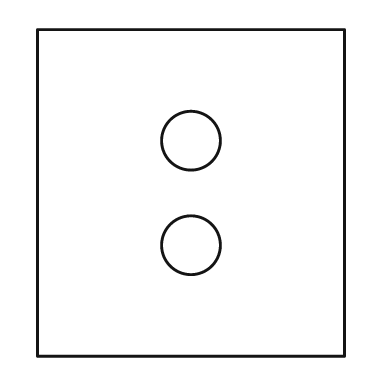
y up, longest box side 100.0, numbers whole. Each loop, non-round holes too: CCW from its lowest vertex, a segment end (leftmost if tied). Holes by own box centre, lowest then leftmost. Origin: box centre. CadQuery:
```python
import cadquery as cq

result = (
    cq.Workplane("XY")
    .moveTo(-47.0, -50.0)
    .lineTo(47.0, -50.0)
    .lineTo(47.0, 50.0)
    .lineTo(-47.0, 50.0)
    .close()
    .moveTo(0.0, -16.0)
    .circle(9.0)
    .moveTo(0.0, 16.0)
    .circle(9.0)
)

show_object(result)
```